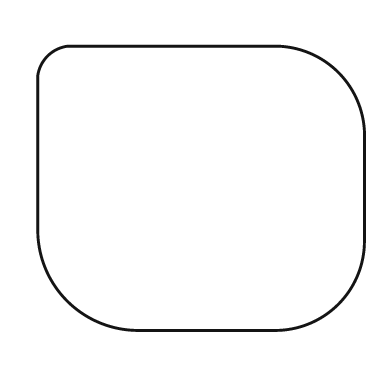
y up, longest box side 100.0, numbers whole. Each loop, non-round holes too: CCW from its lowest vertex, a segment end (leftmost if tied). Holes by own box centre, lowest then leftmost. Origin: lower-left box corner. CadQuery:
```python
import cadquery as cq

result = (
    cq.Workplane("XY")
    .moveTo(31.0, 0.0)
    .lineTo(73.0, 0.0)
    .threePointArc((92.0, 8.0), (100.0, 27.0))
    .lineTo(100.0, 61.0)
    .threePointArc((92.0, 79.0), (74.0, 87.0))
    .lineTo(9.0, 87.0)
    .threePointArc((3.0, 84.0), (0.0, 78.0))
    .lineTo(0.0, 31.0)
    .threePointArc((9.0, 9.0), (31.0, 0.0))
    .close()
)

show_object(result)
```